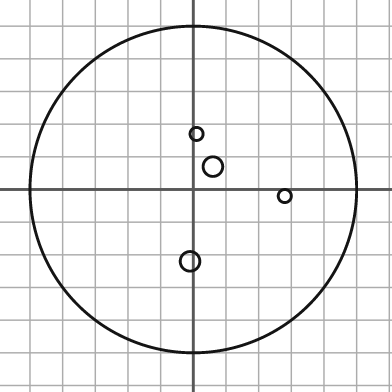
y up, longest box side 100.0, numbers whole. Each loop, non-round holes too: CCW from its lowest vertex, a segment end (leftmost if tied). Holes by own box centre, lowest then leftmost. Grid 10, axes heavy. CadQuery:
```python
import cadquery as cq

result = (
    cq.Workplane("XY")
    .moveTo(0.0, 0.0)
    .circle(50.0)
    .moveTo(-1.0, -22.0)
    .circle(3.0)
    .moveTo(28.0, -2.0)
    .circle(2.0)
    .moveTo(6.0, 7.0)
    .circle(3.0)
    .moveTo(1.0, 17.0)
    .circle(2.0)
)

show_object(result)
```